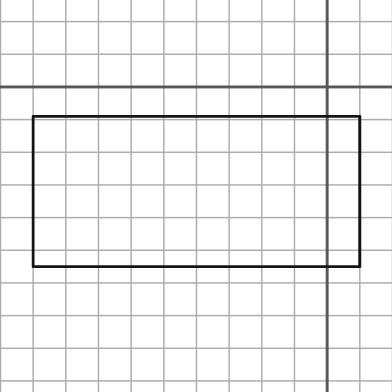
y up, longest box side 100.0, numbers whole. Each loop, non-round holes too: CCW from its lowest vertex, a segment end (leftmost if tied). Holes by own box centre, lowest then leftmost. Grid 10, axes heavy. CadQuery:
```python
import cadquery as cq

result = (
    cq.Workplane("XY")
    .moveTo(-90.0, -55.0)
    .lineTo(10.0, -55.0)
    .lineTo(10.0, -9.0)
    .lineTo(-90.0, -9.0)
    .close()
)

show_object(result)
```